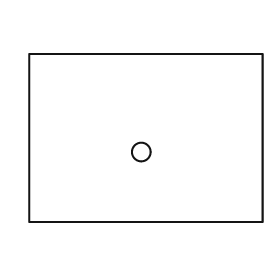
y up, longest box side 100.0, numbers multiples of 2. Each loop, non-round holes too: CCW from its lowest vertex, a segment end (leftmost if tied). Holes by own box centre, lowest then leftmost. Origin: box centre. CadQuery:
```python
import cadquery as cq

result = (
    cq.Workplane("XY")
    .moveTo(-50.0, -36.0)
    .lineTo(50.0, -36.0)
    .lineTo(50.0, 36.0)
    .lineTo(-50.0, 36.0)
    .close()
    .moveTo(-2.0, -6.0)
    .circle(4.0)
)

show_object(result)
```